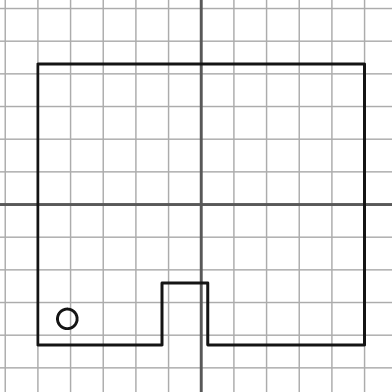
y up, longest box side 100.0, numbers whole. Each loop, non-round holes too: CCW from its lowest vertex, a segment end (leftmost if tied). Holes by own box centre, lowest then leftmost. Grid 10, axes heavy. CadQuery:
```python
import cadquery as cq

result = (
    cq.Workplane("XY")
    .moveTo(-50.0, -43.0)
    .lineTo(-12.0, -43.0)
    .lineTo(-12.0, -24.0)
    .lineTo(2.0, -24.0)
    .lineTo(2.0, -43.0)
    .lineTo(50.0, -43.0)
    .lineTo(50.0, 43.0)
    .lineTo(-50.0, 43.0)
    .close()
    .moveTo(-41.0, -35.0)
    .circle(3.0)
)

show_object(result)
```